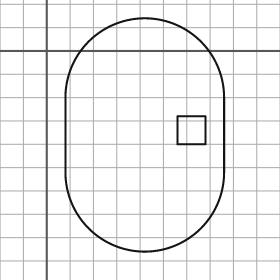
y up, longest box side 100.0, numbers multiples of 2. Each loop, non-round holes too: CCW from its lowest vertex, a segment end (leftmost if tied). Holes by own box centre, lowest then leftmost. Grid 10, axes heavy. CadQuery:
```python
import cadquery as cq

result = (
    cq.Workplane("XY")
    .moveTo(8.0, -52.0)
    .threePointArc((42.0, -86.0), (76.0, -52.0))
    .lineTo(76.0, -20.0)
    .threePointArc((42.0, 14.0), (8.0, -20.0))
    .close()
    .moveTo(56.0, -40.0)
    .lineTo(68.0, -40.0)
    .lineTo(68.0, -28.0)
    .lineTo(56.0, -28.0)
    .close()
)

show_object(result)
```